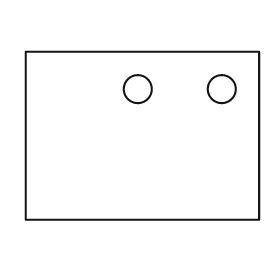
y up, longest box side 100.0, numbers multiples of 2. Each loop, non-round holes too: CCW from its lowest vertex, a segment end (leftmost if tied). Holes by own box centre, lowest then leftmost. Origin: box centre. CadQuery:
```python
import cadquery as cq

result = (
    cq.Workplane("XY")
    .moveTo(-50.0, -36.0)
    .lineTo(50.0, -36.0)
    .lineTo(50.0, 36.0)
    .lineTo(-50.0, 36.0)
    .close()
    .moveTo(-2.0, 20.0)
    .circle(6.0)
    .moveTo(34.0, 20.0)
    .circle(6.0)
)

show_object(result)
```